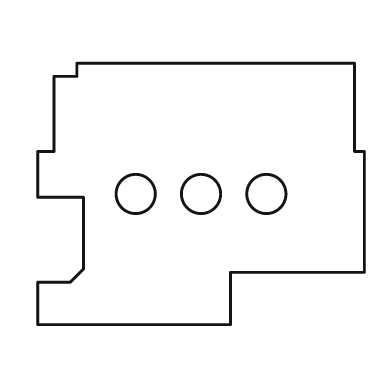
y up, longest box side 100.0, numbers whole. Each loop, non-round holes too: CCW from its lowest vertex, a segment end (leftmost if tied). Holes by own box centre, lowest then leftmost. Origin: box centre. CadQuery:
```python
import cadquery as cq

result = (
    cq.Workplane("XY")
    .moveTo(-50.0, -40.0)
    .lineTo(9.0, -40.0)
    .lineTo(9.0, -24.0)
    .lineTo(50.0, -24.0)
    .lineTo(50.0, 13.0)
    .lineTo(47.0, 13.0)
    .lineTo(47.0, 40.0)
    .lineTo(-38.0, 40.0)
    .lineTo(-38.0, 36.0)
    .lineTo(-45.0, 36.0)
    .lineTo(-45.0, 13.0)
    .lineTo(-50.0, 13.0)
    .lineTo(-50.0, -1.0)
    .lineTo(-36.0, -1.0)
    .lineTo(-36.0, -23.0)
    .lineTo(-40.0, -27.0)
    .lineTo(-50.0, -27.0)
    .close()
    .moveTo(-20.0, 0.0)
    .circle(6.0)
    .moveTo(0.0, 0.0)
    .circle(6.0)
    .moveTo(20.0, 0.0)
    .circle(6.0)
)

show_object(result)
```